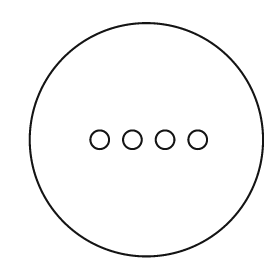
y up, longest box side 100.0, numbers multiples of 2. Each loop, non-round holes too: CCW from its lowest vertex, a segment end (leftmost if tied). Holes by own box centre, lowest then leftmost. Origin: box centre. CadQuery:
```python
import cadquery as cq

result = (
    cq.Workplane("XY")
    .moveTo(0.0, 0.0)
    .circle(50.0)
    .moveTo(-20.0, 0.0)
    .circle(4.0)
    .moveTo(-6.0, 0.0)
    .circle(4.0)
    .moveTo(8.0, 0.0)
    .circle(4.0)
    .moveTo(22.0, 0.0)
    .circle(4.0)
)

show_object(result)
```